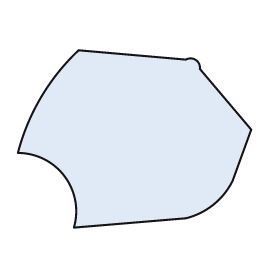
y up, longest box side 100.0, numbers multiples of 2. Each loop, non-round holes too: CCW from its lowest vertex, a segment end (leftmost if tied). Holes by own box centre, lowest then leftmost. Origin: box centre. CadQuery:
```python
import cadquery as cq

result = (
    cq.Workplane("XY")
    .moveTo(-26.0, -38.0)
    .lineTo(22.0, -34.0)
    .threePointArc((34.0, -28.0), (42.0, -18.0))
    .lineTo(50.0, 4.0)
    .lineTo(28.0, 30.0)
    .threePointArc((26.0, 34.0), (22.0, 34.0))
    .lineTo(-24.0, 38.0)
    .threePointArc((-40.0, 18.0), (-50.0, -6.0))
    .threePointArc((-30.0, -16.0), (-26.0, -38.0))
    .close()
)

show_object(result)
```